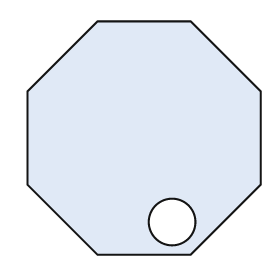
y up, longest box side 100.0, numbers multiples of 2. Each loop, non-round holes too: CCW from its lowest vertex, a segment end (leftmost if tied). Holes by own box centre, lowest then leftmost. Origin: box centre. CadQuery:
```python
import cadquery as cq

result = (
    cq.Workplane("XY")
    .moveTo(-20.0, -50.0)
    .lineTo(20.0, -50.0)
    .lineTo(50.0, -20.0)
    .lineTo(50.0, 20.0)
    .lineTo(20.0, 50.0)
    .lineTo(-20.0, 50.0)
    .lineTo(-50.0, 20.0)
    .lineTo(-50.0, -20.0)
    .close()
    .moveTo(12.0, -36.0)
    .circle(10.0)
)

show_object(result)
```